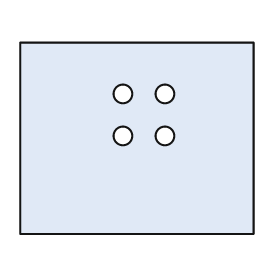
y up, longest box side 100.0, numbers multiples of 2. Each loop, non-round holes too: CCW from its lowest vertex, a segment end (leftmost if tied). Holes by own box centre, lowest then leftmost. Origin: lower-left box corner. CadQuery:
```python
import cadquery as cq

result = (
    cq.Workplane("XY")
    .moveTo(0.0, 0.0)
    .lineTo(100.0, 0.0)
    .lineTo(100.0, 82.0)
    .lineTo(0.0, 82.0)
    .close()
    .moveTo(44.0, 42.0)
    .circle(4.0)
    .moveTo(62.0, 42.0)
    .circle(4.0)
    .moveTo(44.0, 60.0)
    .circle(4.0)
    .moveTo(62.0, 60.0)
    .circle(4.0)
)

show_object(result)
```